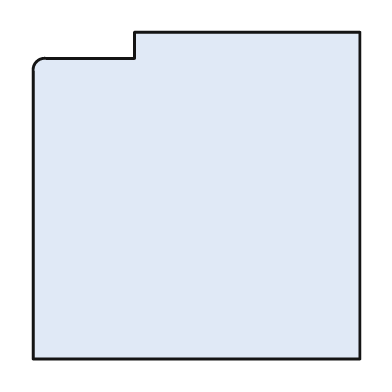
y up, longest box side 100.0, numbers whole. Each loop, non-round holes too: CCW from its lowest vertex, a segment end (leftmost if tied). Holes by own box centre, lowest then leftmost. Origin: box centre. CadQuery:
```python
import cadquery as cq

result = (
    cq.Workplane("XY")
    .moveTo(-50.0, -50.0)
    .lineTo(50.0, -50.0)
    .lineTo(50.0, 50.0)
    .lineTo(-19.0, 50.0)
    .lineTo(-19.0, 42.0)
    .lineTo(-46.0, 42.0)
    .threePointArc((-49.0, 41.0), (-50.0, 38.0))
    .close()
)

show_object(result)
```